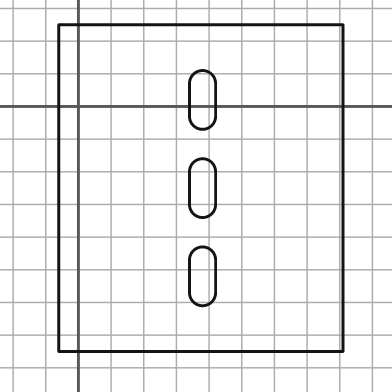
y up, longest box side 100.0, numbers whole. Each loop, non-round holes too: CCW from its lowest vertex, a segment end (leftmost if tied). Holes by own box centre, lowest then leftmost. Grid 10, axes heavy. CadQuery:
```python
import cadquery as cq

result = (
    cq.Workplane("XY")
    .moveTo(-6.0, -75.0)
    .lineTo(81.0, -75.0)
    .lineTo(81.0, 25.0)
    .lineTo(-6.0, 25.0)
    .close()
    .moveTo(34.0, -57.0)
    .threePointArc((38.0, -61.0), (42.0, -57.0))
    .lineTo(42.0, -47.0)
    .threePointArc((38.0, -43.0), (34.0, -47.0))
    .close()
    .moveTo(34.0, -30.0)
    .threePointArc((38.0, -34.0), (42.0, -30.0))
    .lineTo(42.0, -20.0)
    .threePointArc((38.0, -16.0), (34.0, -20.0))
    .close()
    .moveTo(34.0, -3.0)
    .threePointArc((38.0, -7.0), (42.0, -3.0))
    .lineTo(42.0, 7.0)
    .threePointArc((38.0, 11.0), (34.0, 7.0))
    .close()
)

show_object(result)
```